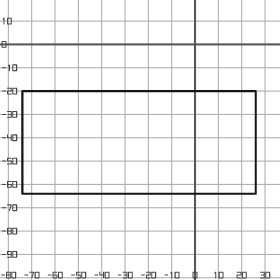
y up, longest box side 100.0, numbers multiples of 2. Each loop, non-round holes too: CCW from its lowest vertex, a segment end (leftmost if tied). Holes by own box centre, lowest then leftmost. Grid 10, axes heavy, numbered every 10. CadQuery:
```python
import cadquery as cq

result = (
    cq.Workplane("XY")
    .moveTo(-74.0, -64.0)
    .lineTo(26.0, -64.0)
    .lineTo(26.0, -20.0)
    .lineTo(-74.0, -20.0)
    .close()
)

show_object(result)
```